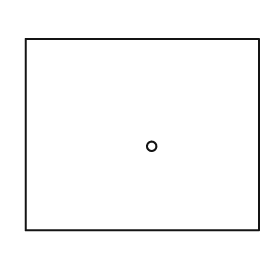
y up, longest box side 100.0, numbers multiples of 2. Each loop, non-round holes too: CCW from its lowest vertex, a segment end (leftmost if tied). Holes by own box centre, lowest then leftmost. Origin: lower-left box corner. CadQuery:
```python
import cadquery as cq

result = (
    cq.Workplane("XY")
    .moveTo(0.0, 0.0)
    .lineTo(100.0, 0.0)
    .lineTo(100.0, 82.0)
    .lineTo(0.0, 82.0)
    .close()
    .moveTo(54.0, 36.0)
    .circle(2.0)
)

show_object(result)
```